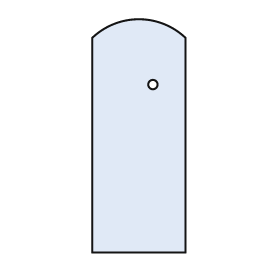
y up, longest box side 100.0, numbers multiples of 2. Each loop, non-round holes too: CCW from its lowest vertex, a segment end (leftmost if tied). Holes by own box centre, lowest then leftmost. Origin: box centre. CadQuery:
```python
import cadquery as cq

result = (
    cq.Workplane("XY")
    .moveTo(-20.0, -50.0)
    .lineTo(20.0, -50.0)
    .lineTo(20.0, 42.0)
    .threePointArc((0.0, 50.0), (-20.0, 42.0))
    .close()
    .moveTo(6.0, 22.0)
    .circle(2.0)
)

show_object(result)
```